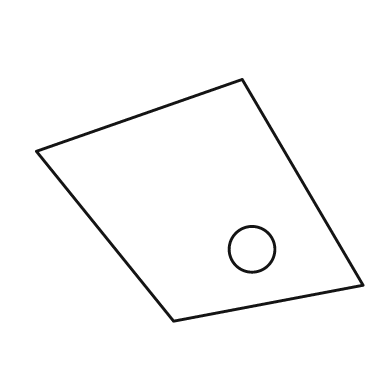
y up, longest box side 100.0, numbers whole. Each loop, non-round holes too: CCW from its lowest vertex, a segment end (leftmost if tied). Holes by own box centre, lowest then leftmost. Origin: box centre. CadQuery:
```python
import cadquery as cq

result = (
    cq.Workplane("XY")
    .moveTo(-8.0, -37.0)
    .lineTo(50.0, -26.0)
    .lineTo(13.0, 37.0)
    .lineTo(-50.0, 15.0)
    .close()
    .moveTo(16.0, -15.0)
    .circle(7.0)
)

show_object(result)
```